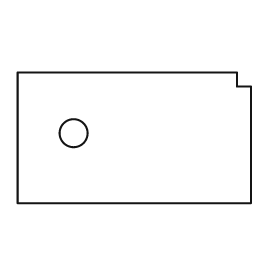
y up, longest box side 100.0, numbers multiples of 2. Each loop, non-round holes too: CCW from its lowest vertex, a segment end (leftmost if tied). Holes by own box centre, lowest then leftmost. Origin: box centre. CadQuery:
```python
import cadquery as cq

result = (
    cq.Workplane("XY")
    .moveTo(-50.0, -28.0)
    .lineTo(50.0, -28.0)
    .lineTo(50.0, 22.0)
    .lineTo(44.0, 22.0)
    .lineTo(44.0, 28.0)
    .lineTo(-50.0, 28.0)
    .close()
    .moveTo(-26.0, 2.0)
    .circle(6.0)
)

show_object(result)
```